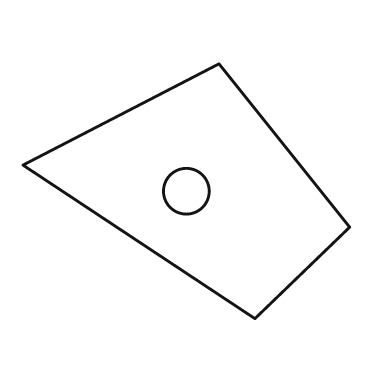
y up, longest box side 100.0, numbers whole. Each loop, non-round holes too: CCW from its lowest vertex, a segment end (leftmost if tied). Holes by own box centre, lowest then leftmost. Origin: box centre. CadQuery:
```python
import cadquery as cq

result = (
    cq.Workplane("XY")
    .moveTo(21.0, -39.0)
    .lineTo(50.0, -11.0)
    .lineTo(10.0, 39.0)
    .lineTo(-50.0, 8.0)
    .close()
    .moveTo(0.0, 0.0)
    .circle(7.0)
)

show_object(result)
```